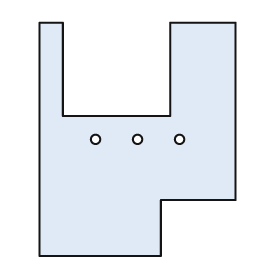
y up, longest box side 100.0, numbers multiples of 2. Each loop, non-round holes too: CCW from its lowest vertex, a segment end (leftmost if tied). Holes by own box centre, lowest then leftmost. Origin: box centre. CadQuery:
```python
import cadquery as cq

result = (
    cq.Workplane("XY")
    .moveTo(-42.0, -50.0)
    .lineTo(10.0, -50.0)
    .lineTo(10.0, -26.0)
    .lineTo(42.0, -26.0)
    .lineTo(42.0, 50.0)
    .lineTo(14.0, 50.0)
    .lineTo(14.0, 10.0)
    .lineTo(-32.0, 10.0)
    .lineTo(-32.0, 50.0)
    .lineTo(-42.0, 50.0)
    .close()
    .moveTo(-18.0, 0.0)
    .circle(2.0)
    .moveTo(0.0, 0.0)
    .circle(2.0)
    .moveTo(18.0, 0.0)
    .circle(2.0)
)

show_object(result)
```